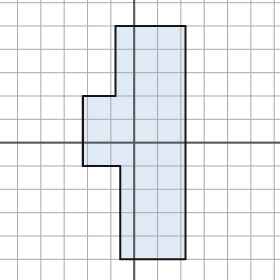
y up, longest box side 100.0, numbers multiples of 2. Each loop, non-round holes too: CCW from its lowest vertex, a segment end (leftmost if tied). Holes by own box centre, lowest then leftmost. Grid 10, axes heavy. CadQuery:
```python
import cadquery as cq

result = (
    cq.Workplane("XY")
    .moveTo(-6.0, -50.0)
    .lineTo(22.0, -50.0)
    .lineTo(22.0, 50.0)
    .lineTo(-8.0, 50.0)
    .lineTo(-8.0, 20.0)
    .lineTo(-22.0, 20.0)
    .lineTo(-22.0, -10.0)
    .lineTo(-6.0, -10.0)
    .close()
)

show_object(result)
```